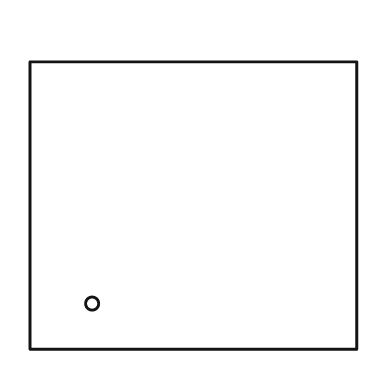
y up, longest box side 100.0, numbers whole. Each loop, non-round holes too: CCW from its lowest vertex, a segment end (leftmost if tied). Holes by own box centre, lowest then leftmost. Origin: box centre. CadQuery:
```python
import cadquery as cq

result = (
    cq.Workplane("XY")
    .moveTo(-50.0, -44.0)
    .lineTo(50.0, -44.0)
    .lineTo(50.0, 44.0)
    .lineTo(-50.0, 44.0)
    .close()
    .moveTo(-31.0, -30.0)
    .circle(2.0)
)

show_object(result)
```